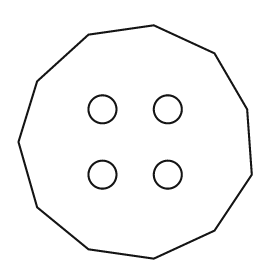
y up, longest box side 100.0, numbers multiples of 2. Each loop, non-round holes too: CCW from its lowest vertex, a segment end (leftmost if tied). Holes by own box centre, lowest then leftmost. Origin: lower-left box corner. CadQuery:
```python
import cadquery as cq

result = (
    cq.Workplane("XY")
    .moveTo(58.0, 0.0)
    .lineTo(84.0, 12.0)
    .lineTo(100.0, 36.0)
    .lineTo(98.0, 64.0)
    .lineTo(84.0, 88.0)
    .lineTo(58.0, 100.0)
    .lineTo(30.0, 96.0)
    .lineTo(8.0, 76.0)
    .lineTo(0.0, 50.0)
    .lineTo(8.0, 22.0)
    .lineTo(30.0, 4.0)
    .close()
    .moveTo(36.0, 36.0)
    .circle(6.0)
    .moveTo(64.0, 36.0)
    .circle(6.0)
    .moveTo(36.0, 64.0)
    .circle(6.0)
    .moveTo(64.0, 64.0)
    .circle(6.0)
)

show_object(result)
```